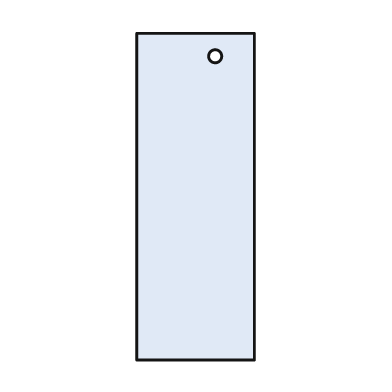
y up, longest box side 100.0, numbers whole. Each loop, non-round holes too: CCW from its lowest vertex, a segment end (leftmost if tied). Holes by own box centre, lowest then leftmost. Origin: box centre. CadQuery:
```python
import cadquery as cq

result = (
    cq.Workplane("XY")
    .moveTo(-18.0, -50.0)
    .lineTo(18.0, -50.0)
    .lineTo(18.0, 50.0)
    .lineTo(-18.0, 50.0)
    .close()
    .moveTo(6.0, 43.0)
    .circle(2.0)
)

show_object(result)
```